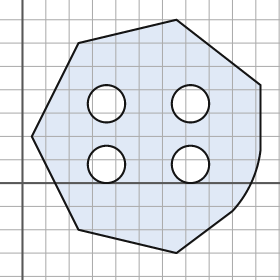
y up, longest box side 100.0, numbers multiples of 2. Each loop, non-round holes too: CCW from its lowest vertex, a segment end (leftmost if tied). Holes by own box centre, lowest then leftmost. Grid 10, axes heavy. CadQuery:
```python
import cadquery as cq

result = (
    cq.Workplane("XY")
    .moveTo(66.0, -30.0)
    .lineTo(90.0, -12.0)
    .threePointArc((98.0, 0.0), (102.0, 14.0))
    .lineTo(102.0, 42.0)
    .lineTo(66.0, 70.0)
    .lineTo(24.0, 60.0)
    .lineTo(4.0, 20.0)
    .lineTo(24.0, -20.0)
    .close()
    .moveTo(36.0, 8.0)
    .circle(8.0)
    .moveTo(72.0, 8.0)
    .circle(8.0)
    .moveTo(36.0, 34.0)
    .circle(8.0)
    .moveTo(72.0, 34.0)
    .circle(8.0)
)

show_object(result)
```